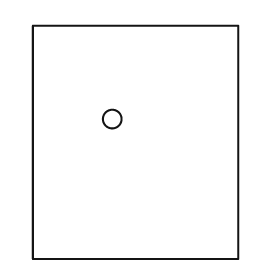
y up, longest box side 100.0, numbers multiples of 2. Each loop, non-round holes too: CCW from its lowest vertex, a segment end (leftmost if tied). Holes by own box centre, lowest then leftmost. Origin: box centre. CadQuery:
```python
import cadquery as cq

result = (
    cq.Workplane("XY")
    .moveTo(-44.0, -50.0)
    .lineTo(44.0, -50.0)
    .lineTo(44.0, 50.0)
    .lineTo(-44.0, 50.0)
    .close()
    .moveTo(-10.0, 10.0)
    .circle(4.0)
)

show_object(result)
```